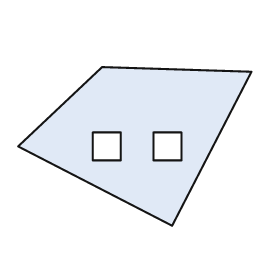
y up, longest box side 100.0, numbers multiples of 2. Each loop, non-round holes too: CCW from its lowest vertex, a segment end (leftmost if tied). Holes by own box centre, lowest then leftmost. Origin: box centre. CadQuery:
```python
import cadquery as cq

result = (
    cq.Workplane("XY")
    .moveTo(16.0, -34.0)
    .lineTo(50.0, 32.0)
    .lineTo(-14.0, 34.0)
    .lineTo(-50.0, 0.0)
    .close()
    .moveTo(-18.0, -6.0)
    .lineTo(-6.0, -6.0)
    .lineTo(-6.0, 6.0)
    .lineTo(-18.0, 6.0)
    .close()
    .moveTo(8.0, -6.0)
    .lineTo(20.0, -6.0)
    .lineTo(20.0, 6.0)
    .lineTo(8.0, 6.0)
    .close()
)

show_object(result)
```